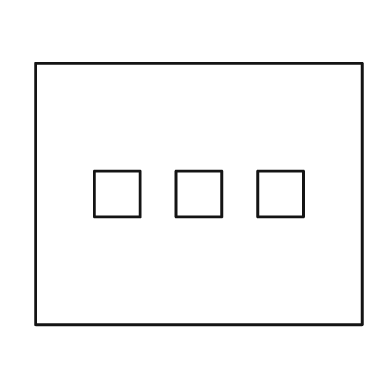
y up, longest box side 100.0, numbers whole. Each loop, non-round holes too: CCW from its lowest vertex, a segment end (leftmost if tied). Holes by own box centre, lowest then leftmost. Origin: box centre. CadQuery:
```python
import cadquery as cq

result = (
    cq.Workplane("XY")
    .moveTo(-50.0, -40.0)
    .lineTo(50.0, -40.0)
    .lineTo(50.0, 40.0)
    .lineTo(-50.0, 40.0)
    .close()
    .moveTo(-32.0, -7.0)
    .lineTo(-18.0, -7.0)
    .lineTo(-18.0, 7.0)
    .lineTo(-32.0, 7.0)
    .close()
    .moveTo(-7.0, -7.0)
    .lineTo(7.0, -7.0)
    .lineTo(7.0, 7.0)
    .lineTo(-7.0, 7.0)
    .close()
    .moveTo(18.0, -7.0)
    .lineTo(32.0, -7.0)
    .lineTo(32.0, 7.0)
    .lineTo(18.0, 7.0)
    .close()
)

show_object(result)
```